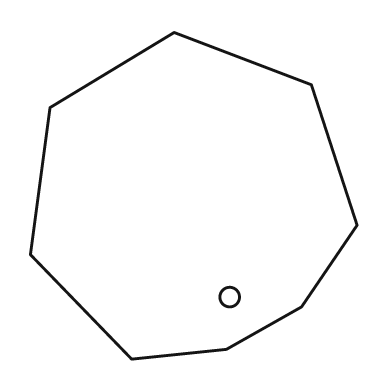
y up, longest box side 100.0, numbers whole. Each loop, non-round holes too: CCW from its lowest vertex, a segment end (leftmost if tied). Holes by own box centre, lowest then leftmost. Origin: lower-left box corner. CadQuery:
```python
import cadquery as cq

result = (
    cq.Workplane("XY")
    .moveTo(31.0, 0.0)
    .lineTo(60.0, 3.0)
    .lineTo(83.0, 16.0)
    .lineTo(100.0, 41.0)
    .lineTo(86.0, 84.0)
    .lineTo(44.0, 100.0)
    .lineTo(6.0, 77.0)
    .lineTo(0.0, 32.0)
    .close()
    .moveTo(61.0, 19.0)
    .circle(3.0)
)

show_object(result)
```